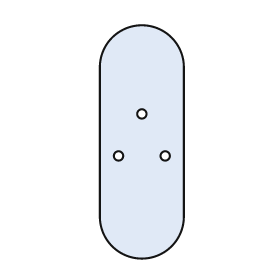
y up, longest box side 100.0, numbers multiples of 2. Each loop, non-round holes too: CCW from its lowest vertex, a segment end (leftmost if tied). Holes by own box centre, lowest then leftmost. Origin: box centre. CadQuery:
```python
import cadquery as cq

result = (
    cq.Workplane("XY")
    .moveTo(-18.0, -32.0)
    .threePointArc((0.0, -50.0), (18.0, -32.0))
    .lineTo(18.0, 32.0)
    .threePointArc((0.0, 50.0), (-18.0, 32.0))
    .close()
    .moveTo(-10.0, -6.0)
    .circle(2.0)
    .moveTo(10.0, -6.0)
    .circle(2.0)
    .moveTo(0.0, 12.0)
    .circle(2.0)
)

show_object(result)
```